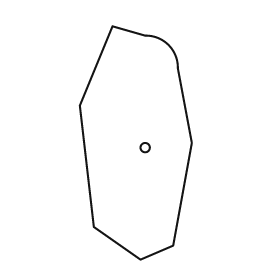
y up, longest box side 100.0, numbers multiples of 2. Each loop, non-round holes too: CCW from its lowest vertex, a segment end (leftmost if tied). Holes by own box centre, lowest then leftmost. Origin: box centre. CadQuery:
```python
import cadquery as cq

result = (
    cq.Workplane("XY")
    .moveTo(2.0, -50.0)
    .lineTo(16.0, -44.0)
    .lineTo(24.0, 0.0)
    .lineTo(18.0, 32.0)
    .threePointArc((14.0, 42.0), (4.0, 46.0))
    .lineTo(-10.0, 50.0)
    .lineTo(-24.0, 16.0)
    .lineTo(-18.0, -36.0)
    .close()
    .moveTo(4.0, -2.0)
    .circle(2.0)
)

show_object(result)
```